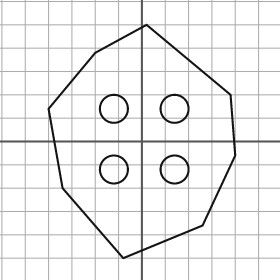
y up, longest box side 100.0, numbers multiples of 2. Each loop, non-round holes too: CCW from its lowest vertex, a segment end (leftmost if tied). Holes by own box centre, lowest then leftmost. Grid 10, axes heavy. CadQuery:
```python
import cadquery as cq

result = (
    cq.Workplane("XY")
    .moveTo(-8.0, -50.0)
    .lineTo(26.0, -36.0)
    .lineTo(40.0, -6.0)
    .lineTo(38.0, 20.0)
    .lineTo(2.0, 50.0)
    .lineTo(-20.0, 38.0)
    .lineTo(-40.0, 14.0)
    .lineTo(-34.0, -20.0)
    .close()
    .moveTo(-12.0, -12.0)
    .circle(6.0)
    .moveTo(14.0, -12.0)
    .circle(6.0)
    .moveTo(-12.0, 14.0)
    .circle(6.0)
    .moveTo(14.0, 14.0)
    .circle(6.0)
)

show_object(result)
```